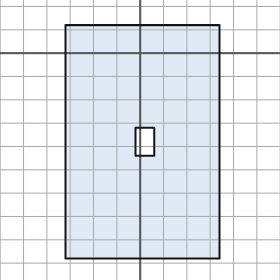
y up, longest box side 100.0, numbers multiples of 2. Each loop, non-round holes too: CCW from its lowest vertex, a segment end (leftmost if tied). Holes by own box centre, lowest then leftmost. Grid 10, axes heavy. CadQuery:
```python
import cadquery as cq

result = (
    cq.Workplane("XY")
    .moveTo(-32.0, -88.0)
    .lineTo(34.0, -88.0)
    .lineTo(34.0, 12.0)
    .lineTo(-32.0, 12.0)
    .close()
    .moveTo(-2.0, -44.0)
    .lineTo(6.0, -44.0)
    .lineTo(6.0, -32.0)
    .lineTo(-2.0, -32.0)
    .close()
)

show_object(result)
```